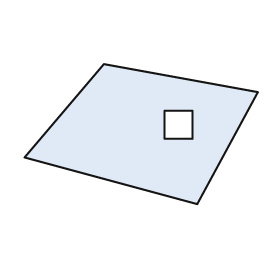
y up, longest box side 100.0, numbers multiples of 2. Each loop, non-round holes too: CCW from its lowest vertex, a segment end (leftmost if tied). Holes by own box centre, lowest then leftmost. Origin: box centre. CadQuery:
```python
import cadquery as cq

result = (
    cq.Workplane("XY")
    .moveTo(24.0, -30.0)
    .lineTo(50.0, 18.0)
    .lineTo(-16.0, 30.0)
    .lineTo(-50.0, -10.0)
    .close()
    .moveTo(10.0, -2.0)
    .lineTo(22.0, -2.0)
    .lineTo(22.0, 10.0)
    .lineTo(10.0, 10.0)
    .close()
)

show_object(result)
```